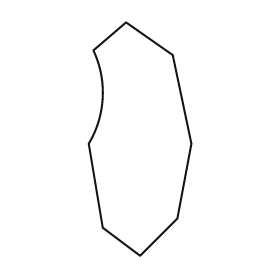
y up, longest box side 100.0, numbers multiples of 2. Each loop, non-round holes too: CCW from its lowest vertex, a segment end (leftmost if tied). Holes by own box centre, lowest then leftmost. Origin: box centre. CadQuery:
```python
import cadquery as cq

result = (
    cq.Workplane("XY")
    .moveTo(0.0, -50.0)
    .lineTo(16.0, -34.0)
    .lineTo(22.0, -2.0)
    .lineTo(14.0, 36.0)
    .lineTo(-6.0, 50.0)
    .lineTo(-20.0, 38.0)
    .threePointArc((-16.0, 18.0), (-22.0, -2.0))
    .lineTo(-16.0, -38.0)
    .close()
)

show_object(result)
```